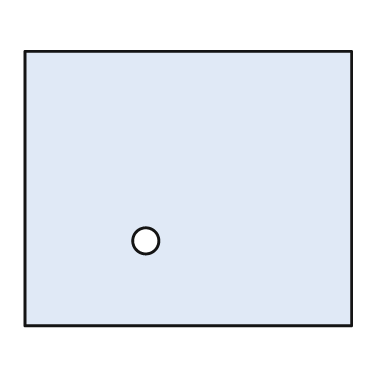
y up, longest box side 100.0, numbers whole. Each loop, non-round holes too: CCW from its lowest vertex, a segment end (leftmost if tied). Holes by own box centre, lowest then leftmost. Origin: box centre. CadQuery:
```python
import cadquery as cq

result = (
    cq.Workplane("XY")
    .moveTo(-50.0, -42.0)
    .lineTo(50.0, -42.0)
    .lineTo(50.0, 42.0)
    .lineTo(-50.0, 42.0)
    .close()
    .moveTo(-13.0, -16.0)
    .circle(4.0)
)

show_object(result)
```